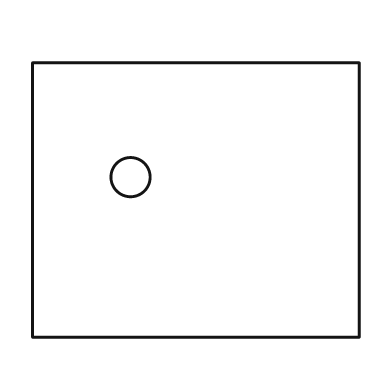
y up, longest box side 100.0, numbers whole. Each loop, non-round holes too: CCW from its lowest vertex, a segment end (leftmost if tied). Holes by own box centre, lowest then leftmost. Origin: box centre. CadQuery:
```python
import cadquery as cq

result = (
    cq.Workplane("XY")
    .moveTo(-50.0, -42.0)
    .lineTo(50.0, -42.0)
    .lineTo(50.0, 42.0)
    .lineTo(-50.0, 42.0)
    .close()
    .moveTo(-20.0, 7.0)
    .circle(6.0)
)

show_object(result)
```